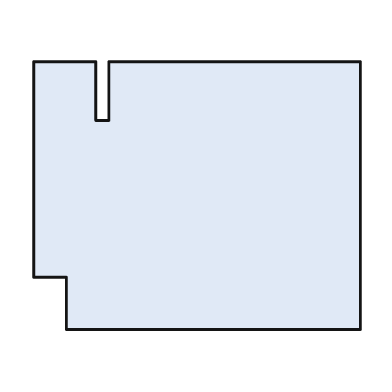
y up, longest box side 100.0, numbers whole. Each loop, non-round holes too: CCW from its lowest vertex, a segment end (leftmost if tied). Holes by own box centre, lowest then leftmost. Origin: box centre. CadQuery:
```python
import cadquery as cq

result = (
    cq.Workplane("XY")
    .moveTo(-40.0, -41.0)
    .lineTo(50.0, -41.0)
    .lineTo(50.0, 41.0)
    .lineTo(-27.0, 41.0)
    .lineTo(-27.0, 23.0)
    .lineTo(-31.0, 23.0)
    .lineTo(-31.0, 41.0)
    .lineTo(-50.0, 41.0)
    .lineTo(-50.0, -25.0)
    .lineTo(-40.0, -25.0)
    .close()
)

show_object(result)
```